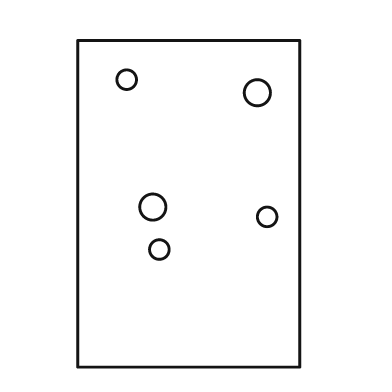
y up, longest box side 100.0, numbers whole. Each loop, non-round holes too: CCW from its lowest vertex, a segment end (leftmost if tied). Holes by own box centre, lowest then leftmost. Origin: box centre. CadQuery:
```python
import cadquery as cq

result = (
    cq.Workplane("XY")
    .moveTo(-34.0, -50.0)
    .lineTo(34.0, -50.0)
    .lineTo(34.0, 50.0)
    .lineTo(-34.0, 50.0)
    .close()
    .moveTo(-9.0, -14.0)
    .circle(3.0)
    .moveTo(24.0, -4.0)
    .circle(3.0)
    .moveTo(-11.0, -1.0)
    .circle(4.0)
    .moveTo(21.0, 34.0)
    .circle(4.0)
    .moveTo(-19.0, 38.0)
    .circle(3.0)
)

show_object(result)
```